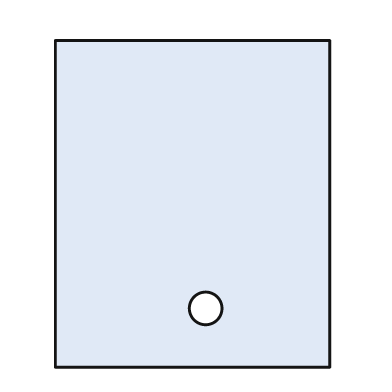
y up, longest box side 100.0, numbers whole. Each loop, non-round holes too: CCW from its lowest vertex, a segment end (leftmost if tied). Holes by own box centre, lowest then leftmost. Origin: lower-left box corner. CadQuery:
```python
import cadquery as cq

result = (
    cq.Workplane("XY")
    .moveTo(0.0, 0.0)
    .lineTo(84.0, 0.0)
    .lineTo(84.0, 100.0)
    .lineTo(0.0, 100.0)
    .close()
    .moveTo(46.0, 18.0)
    .circle(5.0)
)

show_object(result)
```